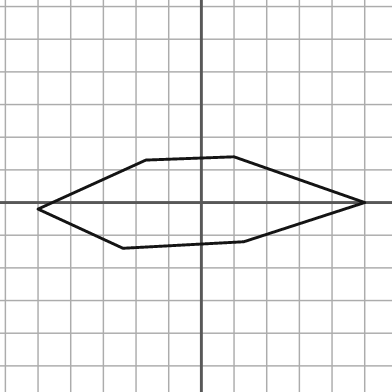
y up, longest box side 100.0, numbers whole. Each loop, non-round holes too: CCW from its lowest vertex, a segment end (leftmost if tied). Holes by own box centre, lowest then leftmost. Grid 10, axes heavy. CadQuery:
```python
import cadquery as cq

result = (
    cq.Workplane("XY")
    .moveTo(-24.0, -14.0)
    .lineTo(13.0, -12.0)
    .lineTo(50.0, 0.0)
    .lineTo(10.0, 14.0)
    .lineTo(-17.0, 13.0)
    .lineTo(-50.0, -2.0)
    .close()
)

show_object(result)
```